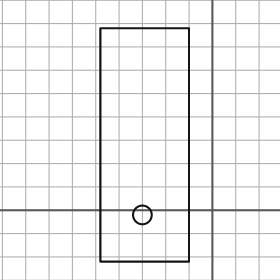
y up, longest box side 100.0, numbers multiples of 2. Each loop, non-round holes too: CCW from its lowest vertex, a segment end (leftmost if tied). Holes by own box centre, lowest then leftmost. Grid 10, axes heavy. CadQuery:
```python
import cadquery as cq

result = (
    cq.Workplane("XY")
    .moveTo(-48.0, -22.0)
    .lineTo(-10.0, -22.0)
    .lineTo(-10.0, 78.0)
    .lineTo(-48.0, 78.0)
    .close()
    .moveTo(-30.0, -2.0)
    .circle(4.0)
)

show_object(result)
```